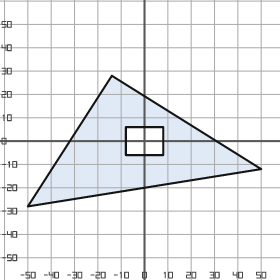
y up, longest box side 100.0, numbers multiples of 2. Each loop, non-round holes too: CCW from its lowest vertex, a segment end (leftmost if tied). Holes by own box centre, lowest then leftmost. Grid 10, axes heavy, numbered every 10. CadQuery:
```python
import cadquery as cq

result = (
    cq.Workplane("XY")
    .moveTo(-50.0, -28.0)
    .lineTo(50.0, -12.0)
    .lineTo(-14.0, 28.0)
    .close()
    .moveTo(-8.0, -6.0)
    .lineTo(8.0, -6.0)
    .lineTo(8.0, 6.0)
    .lineTo(-8.0, 6.0)
    .close()
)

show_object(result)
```